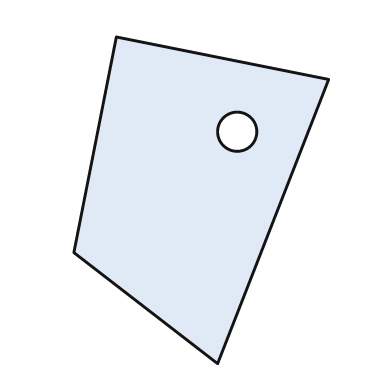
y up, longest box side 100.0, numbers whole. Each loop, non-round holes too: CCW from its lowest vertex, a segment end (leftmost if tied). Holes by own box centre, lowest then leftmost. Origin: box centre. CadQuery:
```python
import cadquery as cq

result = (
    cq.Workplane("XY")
    .moveTo(5.0, -50.0)
    .lineTo(39.0, 37.0)
    .lineTo(-26.0, 50.0)
    .lineTo(-39.0, -16.0)
    .close()
    .moveTo(11.0, 21.0)
    .circle(6.0)
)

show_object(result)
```